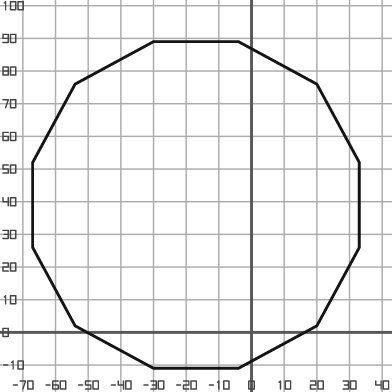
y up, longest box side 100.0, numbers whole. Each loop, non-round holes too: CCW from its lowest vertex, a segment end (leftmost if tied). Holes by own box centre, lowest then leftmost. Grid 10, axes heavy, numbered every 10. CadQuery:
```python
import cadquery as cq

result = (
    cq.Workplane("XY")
    .moveTo(-30.0, -11.0)
    .lineTo(-4.0, -11.0)
    .lineTo(20.0, 2.0)
    .lineTo(33.0, 26.0)
    .lineTo(33.0, 52.0)
    .lineTo(20.0, 76.0)
    .lineTo(-4.0, 89.0)
    .lineTo(-30.0, 89.0)
    .lineTo(-54.0, 76.0)
    .lineTo(-67.0, 52.0)
    .lineTo(-67.0, 26.0)
    .lineTo(-54.0, 2.0)
    .close()
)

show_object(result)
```